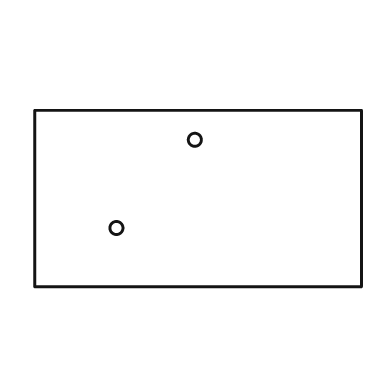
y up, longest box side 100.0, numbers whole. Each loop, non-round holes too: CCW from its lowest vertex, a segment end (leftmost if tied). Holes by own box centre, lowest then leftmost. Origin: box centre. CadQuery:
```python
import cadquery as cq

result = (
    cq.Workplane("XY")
    .moveTo(-50.0, -27.0)
    .lineTo(50.0, -27.0)
    .lineTo(50.0, 27.0)
    .lineTo(-50.0, 27.0)
    .close()
    .moveTo(-25.0, -9.0)
    .circle(2.0)
    .moveTo(-1.0, 18.0)
    .circle(2.0)
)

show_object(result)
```